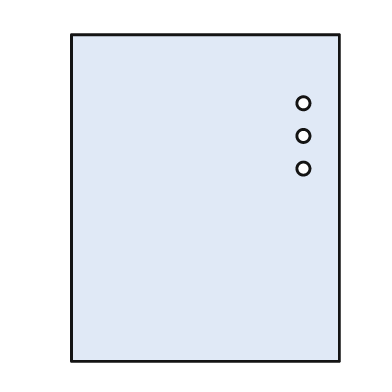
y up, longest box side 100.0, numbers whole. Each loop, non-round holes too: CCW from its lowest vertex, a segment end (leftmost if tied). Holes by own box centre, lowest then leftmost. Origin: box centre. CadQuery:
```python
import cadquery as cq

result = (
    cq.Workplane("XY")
    .moveTo(-41.0, -50.0)
    .lineTo(41.0, -50.0)
    .lineTo(41.0, 50.0)
    .lineTo(-41.0, 50.0)
    .close()
    .moveTo(30.0, 9.0)
    .circle(2.0)
    .moveTo(30.0, 19.0)
    .circle(2.0)
    .moveTo(30.0, 29.0)
    .circle(2.0)
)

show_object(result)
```